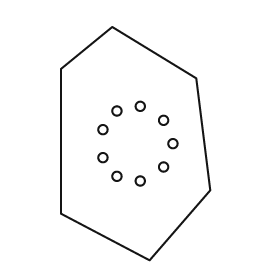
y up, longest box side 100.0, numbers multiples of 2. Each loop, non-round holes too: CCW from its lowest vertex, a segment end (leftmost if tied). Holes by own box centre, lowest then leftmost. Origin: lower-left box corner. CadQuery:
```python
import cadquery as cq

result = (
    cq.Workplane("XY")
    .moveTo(38.0, 0.0)
    .lineTo(64.0, 30.0)
    .lineTo(58.0, 78.0)
    .lineTo(22.0, 100.0)
    .lineTo(0.0, 82.0)
    .lineTo(0.0, 20.0)
    .close()
    .moveTo(34.0, 34.0)
    .circle(2.0)
    .moveTo(24.0, 36.0)
    .circle(2.0)
    .moveTo(44.0, 40.0)
    .circle(2.0)
    .moveTo(18.0, 44.0)
    .circle(2.0)
    .moveTo(48.0, 50.0)
    .circle(2.0)
    .moveTo(18.0, 56.0)
    .circle(2.0)
    .moveTo(44.0, 60.0)
    .circle(2.0)
    .moveTo(24.0, 64.0)
    .circle(2.0)
    .moveTo(34.0, 66.0)
    .circle(2.0)
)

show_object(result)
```